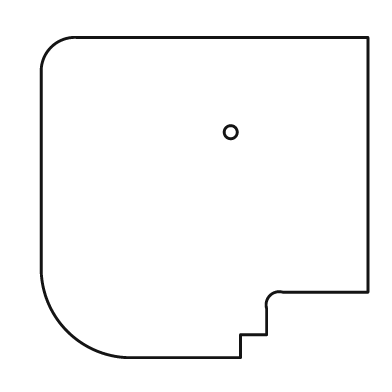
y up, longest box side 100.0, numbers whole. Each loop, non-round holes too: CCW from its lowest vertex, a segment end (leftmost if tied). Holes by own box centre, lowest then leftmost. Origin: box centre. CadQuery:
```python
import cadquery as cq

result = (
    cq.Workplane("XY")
    .moveTo(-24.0, -49.0)
    .lineTo(11.0, -49.0)
    .lineTo(11.0, -42.0)
    .lineTo(19.0, -42.0)
    .lineTo(19.0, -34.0)
    .threePointArc((20.0, -30.0), (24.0, -29.0))
    .lineTo(50.0, -29.0)
    .lineTo(50.0, 49.0)
    .lineTo(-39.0, 49.0)
    .threePointArc((-47.0, 46.0), (-50.0, 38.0))
    .lineTo(-50.0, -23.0)
    .threePointArc((-42.0, -41.0), (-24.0, -49.0))
    .close()
    .moveTo(8.0, 20.0)
    .circle(2.0)
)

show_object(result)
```